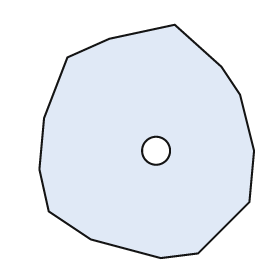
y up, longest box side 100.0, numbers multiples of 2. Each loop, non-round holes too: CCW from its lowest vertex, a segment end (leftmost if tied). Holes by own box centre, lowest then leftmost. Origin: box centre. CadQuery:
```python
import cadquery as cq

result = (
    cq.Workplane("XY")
    .moveTo(6.0, -50.0)
    .lineTo(22.0, -48.0)
    .lineTo(44.0, -26.0)
    .lineTo(46.0, -4.0)
    .lineTo(40.0, 20.0)
    .lineTo(32.0, 32.0)
    .lineTo(12.0, 50.0)
    .lineTo(-16.0, 44.0)
    .lineTo(-34.0, 36.0)
    .lineTo(-44.0, 10.0)
    .lineTo(-46.0, -12.0)
    .lineTo(-42.0, -30.0)
    .lineTo(-24.0, -42.0)
    .close()
    .moveTo(4.0, -4.0)
    .circle(6.0)
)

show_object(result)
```